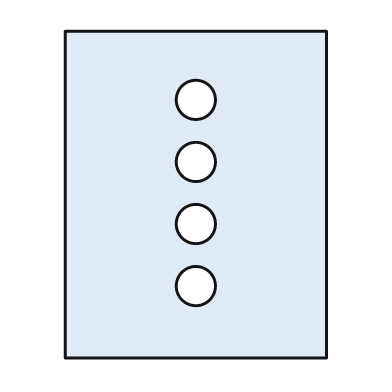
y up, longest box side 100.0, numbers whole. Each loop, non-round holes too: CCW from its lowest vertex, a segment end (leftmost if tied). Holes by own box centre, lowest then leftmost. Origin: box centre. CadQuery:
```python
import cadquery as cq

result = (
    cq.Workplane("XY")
    .moveTo(-40.0, -50.0)
    .lineTo(40.0, -50.0)
    .lineTo(40.0, 50.0)
    .lineTo(-40.0, 50.0)
    .close()
    .moveTo(0.0, -28.0)
    .circle(6.0)
    .moveTo(0.0, -9.0)
    .circle(6.0)
    .moveTo(0.0, 10.0)
    .circle(6.0)
    .moveTo(0.0, 29.0)
    .circle(6.0)
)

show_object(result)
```